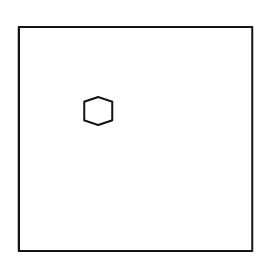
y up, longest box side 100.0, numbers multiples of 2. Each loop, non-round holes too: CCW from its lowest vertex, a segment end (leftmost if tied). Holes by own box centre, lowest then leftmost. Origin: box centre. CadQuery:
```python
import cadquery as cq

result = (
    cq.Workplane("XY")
    .moveTo(-50.0, -48.0)
    .lineTo(50.0, -48.0)
    .lineTo(50.0, 48.0)
    .lineTo(-50.0, 48.0)
    .close()
    .moveTo(-16.0, 6.0)
    .lineTo(-10.0, 8.0)
    .lineTo(-10.0, 16.0)
    .lineTo(-16.0, 18.0)
    .lineTo(-22.0, 16.0)
    .lineTo(-22.0, 8.0)
    .close()
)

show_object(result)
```